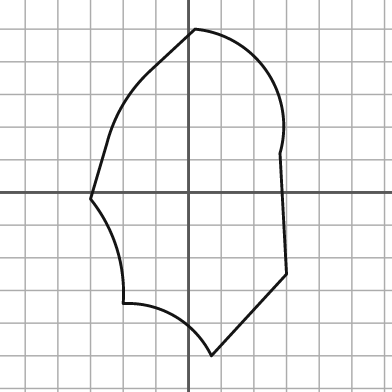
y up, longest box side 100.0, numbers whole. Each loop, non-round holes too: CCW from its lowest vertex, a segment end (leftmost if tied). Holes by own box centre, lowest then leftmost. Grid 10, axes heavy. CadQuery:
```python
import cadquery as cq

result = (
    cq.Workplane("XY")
    .moveTo(7.0, -50.0)
    .lineTo(30.0, -25.0)
    .lineTo(28.0, 12.0)
    .threePointArc((24.0, 37.0), (2.0, 50.0))
    .lineTo(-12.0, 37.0)
    .threePointArc((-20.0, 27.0), (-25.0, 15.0))
    .lineTo(-30.0, -2.0)
    .threePointArc((-22.0, -17.0), (-20.0, -34.0))
    .threePointArc((-4.0, -38.0), (7.0, -50.0))
    .close()
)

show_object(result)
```